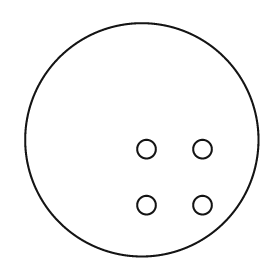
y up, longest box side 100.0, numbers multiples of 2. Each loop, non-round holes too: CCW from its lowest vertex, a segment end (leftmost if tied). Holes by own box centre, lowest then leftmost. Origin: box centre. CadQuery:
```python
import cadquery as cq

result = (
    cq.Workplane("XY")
    .moveTo(0.0, 0.0)
    .circle(50.0)
    .moveTo(2.0, -28.0)
    .circle(4.0)
    .moveTo(26.0, -28.0)
    .circle(4.0)
    .moveTo(2.0, -4.0)
    .circle(4.0)
    .moveTo(26.0, -4.0)
    .circle(4.0)
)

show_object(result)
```